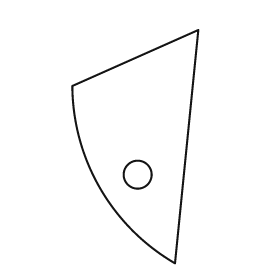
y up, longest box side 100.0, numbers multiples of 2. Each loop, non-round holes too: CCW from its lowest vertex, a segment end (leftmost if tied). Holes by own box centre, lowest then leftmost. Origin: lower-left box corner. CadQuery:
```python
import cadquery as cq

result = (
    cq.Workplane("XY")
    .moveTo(44.0, 0.0)
    .lineTo(54.0, 100.0)
    .lineTo(0.0, 76.0)
    .threePointArc((12.0, 32.0), (44.0, 0.0))
    .close()
    .moveTo(28.0, 38.0)
    .circle(6.0)
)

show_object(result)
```